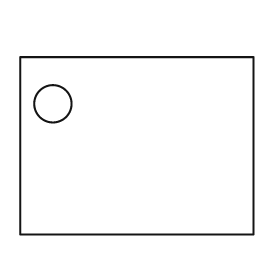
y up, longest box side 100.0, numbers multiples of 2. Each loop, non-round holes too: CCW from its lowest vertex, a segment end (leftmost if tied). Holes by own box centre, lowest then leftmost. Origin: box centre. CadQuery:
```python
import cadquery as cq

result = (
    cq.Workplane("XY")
    .moveTo(-50.0, -38.0)
    .lineTo(50.0, -38.0)
    .lineTo(50.0, 38.0)
    .lineTo(-50.0, 38.0)
    .close()
    .moveTo(-36.0, 18.0)
    .circle(8.0)
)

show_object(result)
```